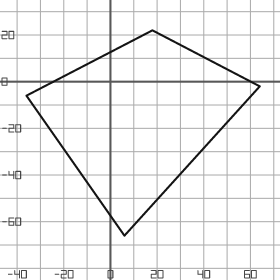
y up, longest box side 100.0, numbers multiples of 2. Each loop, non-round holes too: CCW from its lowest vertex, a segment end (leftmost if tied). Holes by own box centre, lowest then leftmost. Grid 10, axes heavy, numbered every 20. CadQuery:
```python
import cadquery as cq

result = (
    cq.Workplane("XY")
    .moveTo(6.0, -66.0)
    .lineTo(64.0, -2.0)
    .lineTo(18.0, 22.0)
    .lineTo(-36.0, -6.0)
    .close()
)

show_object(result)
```